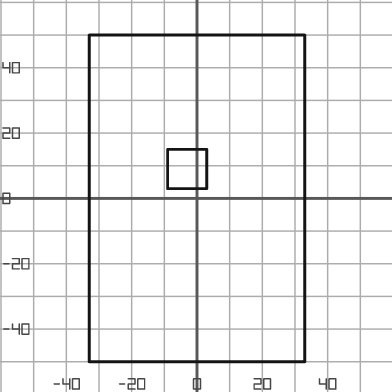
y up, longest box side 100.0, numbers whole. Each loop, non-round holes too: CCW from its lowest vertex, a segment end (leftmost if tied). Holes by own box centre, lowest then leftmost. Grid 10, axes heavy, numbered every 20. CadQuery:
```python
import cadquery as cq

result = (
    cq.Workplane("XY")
    .moveTo(-33.0, -50.0)
    .lineTo(33.0, -50.0)
    .lineTo(33.0, 50.0)
    .lineTo(-33.0, 50.0)
    .close()
    .moveTo(-9.0, 3.0)
    .lineTo(3.0, 3.0)
    .lineTo(3.0, 15.0)
    .lineTo(-9.0, 15.0)
    .close()
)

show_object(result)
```